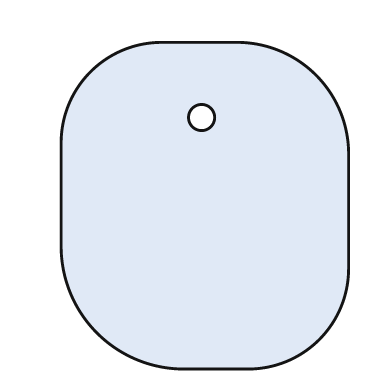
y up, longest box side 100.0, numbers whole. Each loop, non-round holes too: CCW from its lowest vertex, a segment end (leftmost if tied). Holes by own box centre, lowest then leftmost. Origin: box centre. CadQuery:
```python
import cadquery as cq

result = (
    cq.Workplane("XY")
    .moveTo(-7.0, -50.0)
    .lineTo(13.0, -50.0)
    .threePointArc((35.0, -41.0), (44.0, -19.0))
    .lineTo(44.0, 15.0)
    .threePointArc((34.0, 40.0), (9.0, 50.0))
    .lineTo(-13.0, 50.0)
    .threePointArc((-35.0, 41.0), (-44.0, 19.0))
    .lineTo(-44.0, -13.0)
    .threePointArc((-33.0, -39.0), (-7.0, -50.0))
    .close()
    .moveTo(-1.0, 27.0)
    .circle(4.0)
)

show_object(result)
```